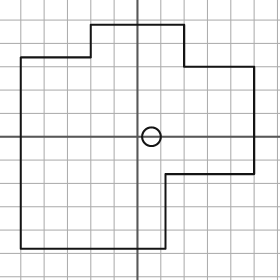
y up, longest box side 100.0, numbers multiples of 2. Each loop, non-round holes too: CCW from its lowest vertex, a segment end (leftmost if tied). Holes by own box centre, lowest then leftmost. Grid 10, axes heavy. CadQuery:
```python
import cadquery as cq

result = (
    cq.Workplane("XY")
    .moveTo(-50.0, -48.0)
    .lineTo(12.0, -48.0)
    .lineTo(12.0, -16.0)
    .lineTo(50.0, -16.0)
    .lineTo(50.0, 30.0)
    .lineTo(20.0, 30.0)
    .lineTo(20.0, 48.0)
    .lineTo(-20.0, 48.0)
    .lineTo(-20.0, 34.0)
    .lineTo(-50.0, 34.0)
    .close()
    .moveTo(6.0, 0.0)
    .circle(4.0)
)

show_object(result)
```